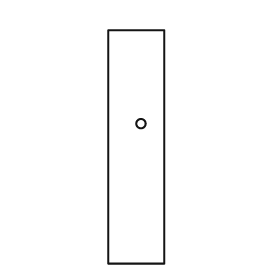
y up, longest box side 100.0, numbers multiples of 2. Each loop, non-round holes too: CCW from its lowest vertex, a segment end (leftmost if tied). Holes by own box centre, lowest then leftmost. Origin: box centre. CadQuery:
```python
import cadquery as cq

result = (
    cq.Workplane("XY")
    .moveTo(-12.0, -50.0)
    .lineTo(12.0, -50.0)
    .lineTo(12.0, 50.0)
    .lineTo(-12.0, 50.0)
    .close()
    .moveTo(2.0, 10.0)
    .circle(2.0)
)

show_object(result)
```